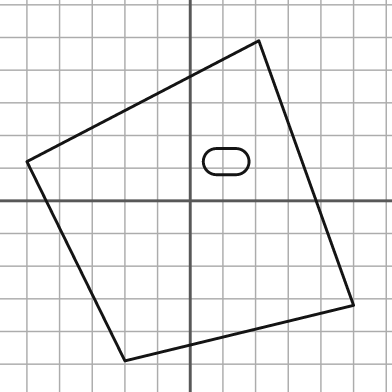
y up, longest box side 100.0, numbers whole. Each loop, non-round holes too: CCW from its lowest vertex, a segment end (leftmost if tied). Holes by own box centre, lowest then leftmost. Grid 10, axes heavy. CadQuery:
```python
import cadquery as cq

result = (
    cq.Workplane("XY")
    .moveTo(-20.0, -49.0)
    .lineTo(50.0, -32.0)
    .lineTo(21.0, 49.0)
    .lineTo(-50.0, 12.0)
    .close()
    .moveTo(8.0, 8.0)
    .lineTo(14.0, 8.0)
    .threePointArc((18.0, 12.0), (14.0, 16.0))
    .lineTo(8.0, 16.0)
    .threePointArc((4.0, 12.0), (8.0, 8.0))
    .close()
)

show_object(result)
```